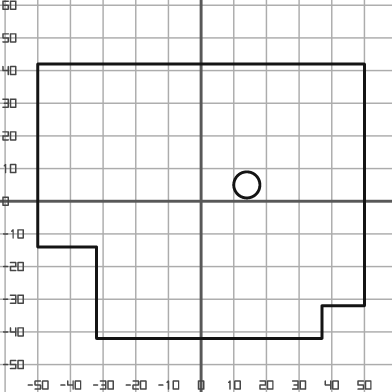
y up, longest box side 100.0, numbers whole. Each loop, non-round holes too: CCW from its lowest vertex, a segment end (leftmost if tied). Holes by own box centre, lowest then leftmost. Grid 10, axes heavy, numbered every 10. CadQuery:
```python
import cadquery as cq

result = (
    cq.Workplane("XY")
    .moveTo(-32.0, -42.0)
    .lineTo(37.0, -42.0)
    .lineTo(37.0, -32.0)
    .lineTo(50.0, -32.0)
    .lineTo(50.0, 42.0)
    .lineTo(-50.0, 42.0)
    .lineTo(-50.0, -14.0)
    .lineTo(-32.0, -14.0)
    .close()
    .moveTo(14.0, 5.0)
    .circle(4.0)
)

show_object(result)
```